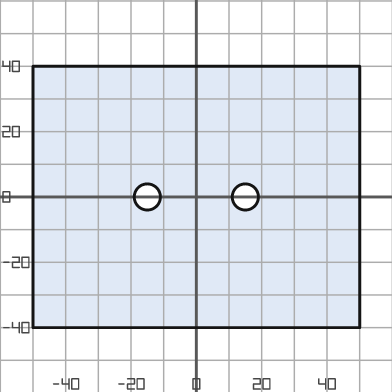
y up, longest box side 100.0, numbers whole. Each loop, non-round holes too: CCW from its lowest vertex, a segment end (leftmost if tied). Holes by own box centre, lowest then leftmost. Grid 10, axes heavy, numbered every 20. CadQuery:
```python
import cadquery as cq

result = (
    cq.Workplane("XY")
    .moveTo(-50.0, -40.0)
    .lineTo(50.0, -40.0)
    .lineTo(50.0, 40.0)
    .lineTo(-50.0, 40.0)
    .close()
    .moveTo(-15.0, 0.0)
    .circle(4.0)
    .moveTo(15.0, 0.0)
    .circle(4.0)
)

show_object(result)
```